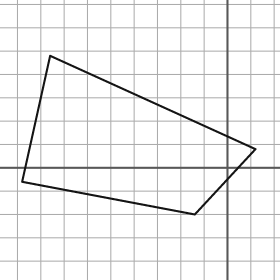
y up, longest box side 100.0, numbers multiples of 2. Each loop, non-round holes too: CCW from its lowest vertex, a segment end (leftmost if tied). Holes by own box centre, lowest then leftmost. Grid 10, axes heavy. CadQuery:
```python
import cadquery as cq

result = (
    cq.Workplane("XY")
    .moveTo(-14.0, -20.0)
    .lineTo(12.0, 8.0)
    .lineTo(-76.0, 48.0)
    .lineTo(-88.0, -6.0)
    .close()
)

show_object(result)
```